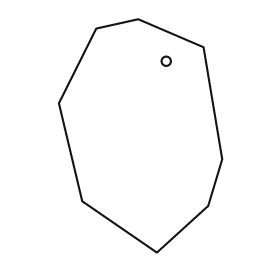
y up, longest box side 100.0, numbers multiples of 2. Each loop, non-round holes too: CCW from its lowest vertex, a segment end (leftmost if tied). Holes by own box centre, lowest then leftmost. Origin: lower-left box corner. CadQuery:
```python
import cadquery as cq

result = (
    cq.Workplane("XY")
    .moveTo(42.0, 0.0)
    .lineTo(64.0, 20.0)
    .lineTo(70.0, 40.0)
    .lineTo(62.0, 88.0)
    .lineTo(34.0, 100.0)
    .lineTo(16.0, 96.0)
    .lineTo(0.0, 64.0)
    .lineTo(10.0, 22.0)
    .close()
    .moveTo(46.0, 82.0)
    .circle(2.0)
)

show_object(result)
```